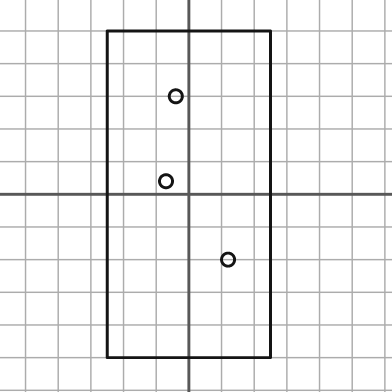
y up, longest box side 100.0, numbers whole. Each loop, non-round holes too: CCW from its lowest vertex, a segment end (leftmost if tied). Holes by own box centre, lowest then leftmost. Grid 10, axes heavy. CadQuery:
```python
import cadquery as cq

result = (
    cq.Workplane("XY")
    .moveTo(-25.0, -50.0)
    .lineTo(25.0, -50.0)
    .lineTo(25.0, 50.0)
    .lineTo(-25.0, 50.0)
    .close()
    .moveTo(12.0, -20.0)
    .circle(2.0)
    .moveTo(-7.0, 4.0)
    .circle(2.0)
    .moveTo(-4.0, 30.0)
    .circle(2.0)
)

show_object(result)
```